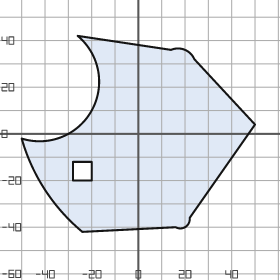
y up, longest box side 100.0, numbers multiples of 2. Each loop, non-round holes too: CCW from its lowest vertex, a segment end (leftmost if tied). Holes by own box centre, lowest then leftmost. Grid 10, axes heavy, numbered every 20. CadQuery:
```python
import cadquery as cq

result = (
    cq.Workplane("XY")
    .moveTo(-24.0, -42.0)
    .lineTo(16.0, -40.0)
    .threePointArc((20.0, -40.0), (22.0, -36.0))
    .lineTo(50.0, 4.0)
    .lineTo(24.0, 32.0)
    .threePointArc((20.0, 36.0), (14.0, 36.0))
    .lineTo(-26.0, 42.0)
    .threePointArc((-20.0, 10.0), (-50.0, -2.0))
    .threePointArc((-40.0, -24.0), (-24.0, -42.0))
    .close()
    .moveTo(-28.0, -20.0)
    .lineTo(-20.0, -20.0)
    .lineTo(-20.0, -12.0)
    .lineTo(-28.0, -12.0)
    .close()
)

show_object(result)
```